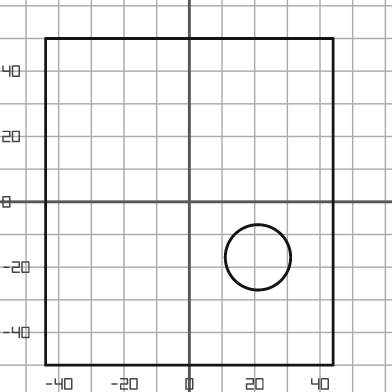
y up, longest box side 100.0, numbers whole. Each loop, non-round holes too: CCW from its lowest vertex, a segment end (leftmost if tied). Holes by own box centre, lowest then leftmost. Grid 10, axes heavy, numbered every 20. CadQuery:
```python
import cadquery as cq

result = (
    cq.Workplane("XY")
    .moveTo(-44.0, -50.0)
    .lineTo(44.0, -50.0)
    .lineTo(44.0, 50.0)
    .lineTo(-44.0, 50.0)
    .close()
    .moveTo(21.0, -17.0)
    .circle(10.0)
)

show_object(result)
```